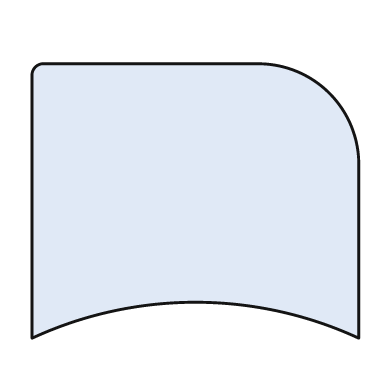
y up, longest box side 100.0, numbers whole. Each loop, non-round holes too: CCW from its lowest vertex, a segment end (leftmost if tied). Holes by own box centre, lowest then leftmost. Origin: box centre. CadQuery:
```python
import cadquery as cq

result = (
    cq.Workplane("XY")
    .moveTo(-50.0, -42.0)
    .threePointArc((0.0, -31.0), (50.0, -42.0))
    .lineTo(50.0, 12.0)
    .threePointArc((41.0, 33.0), (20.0, 42.0))
    .lineTo(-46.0, 42.0)
    .threePointArc((-49.0, 41.0), (-50.0, 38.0))
    .close()
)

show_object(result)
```